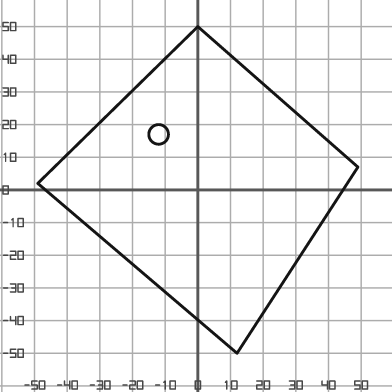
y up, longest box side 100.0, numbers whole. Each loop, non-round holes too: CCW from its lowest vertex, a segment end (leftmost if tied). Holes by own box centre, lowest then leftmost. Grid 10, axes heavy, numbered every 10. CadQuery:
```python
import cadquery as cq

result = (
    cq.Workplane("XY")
    .moveTo(12.0, -50.0)
    .lineTo(49.0, 7.0)
    .lineTo(0.0, 50.0)
    .lineTo(-49.0, 2.0)
    .close()
    .moveTo(-12.0, 17.0)
    .circle(3.0)
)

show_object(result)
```